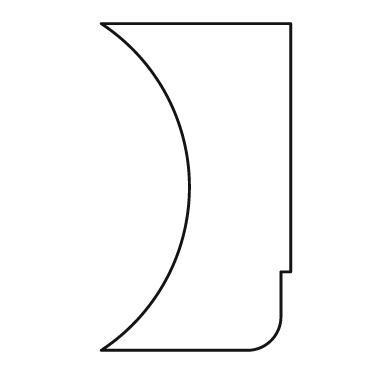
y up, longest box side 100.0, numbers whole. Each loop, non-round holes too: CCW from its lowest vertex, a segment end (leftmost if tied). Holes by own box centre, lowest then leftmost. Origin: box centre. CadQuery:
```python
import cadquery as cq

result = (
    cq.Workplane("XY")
    .moveTo(-29.0, -50.0)
    .lineTo(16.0, -50.0)
    .threePointArc((23.0, -47.0), (26.0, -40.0))
    .lineTo(26.0, -26.0)
    .lineTo(29.0, -26.0)
    .lineTo(29.0, 50.0)
    .lineTo(-29.0, 50.0)
    .threePointArc((-2.0, 0.0), (-29.0, -50.0))
    .close()
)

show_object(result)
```